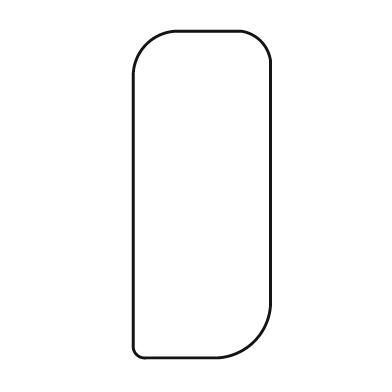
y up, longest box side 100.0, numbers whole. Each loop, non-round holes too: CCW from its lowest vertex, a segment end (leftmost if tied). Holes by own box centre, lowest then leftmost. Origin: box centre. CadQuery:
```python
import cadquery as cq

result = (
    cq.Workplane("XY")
    .moveTo(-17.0, -50.0)
    .lineTo(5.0, -50.0)
    .threePointArc((16.0, -45.0), (21.0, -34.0))
    .lineTo(21.0, 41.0)
    .threePointArc((18.0, 47.0), (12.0, 50.0))
    .lineTo(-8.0, 50.0)
    .threePointArc((-17.0, 46.0), (-21.0, 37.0))
    .lineTo(-21.0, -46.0)
    .threePointArc((-20.0, -49.0), (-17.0, -50.0))
    .close()
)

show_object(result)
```